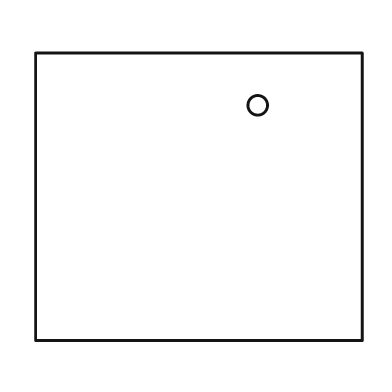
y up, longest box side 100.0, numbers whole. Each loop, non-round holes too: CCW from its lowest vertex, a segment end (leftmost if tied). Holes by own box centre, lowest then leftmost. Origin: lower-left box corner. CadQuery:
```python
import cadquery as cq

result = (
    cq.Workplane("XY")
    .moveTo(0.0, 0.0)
    .lineTo(100.0, 0.0)
    .lineTo(100.0, 88.0)
    .lineTo(0.0, 88.0)
    .close()
    .moveTo(68.0, 72.0)
    .circle(3.0)
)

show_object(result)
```